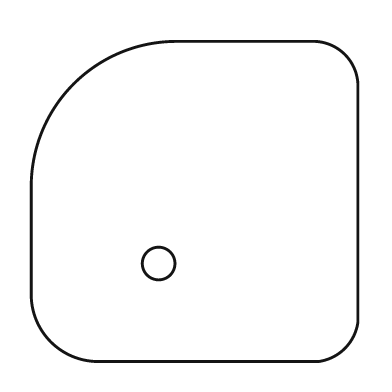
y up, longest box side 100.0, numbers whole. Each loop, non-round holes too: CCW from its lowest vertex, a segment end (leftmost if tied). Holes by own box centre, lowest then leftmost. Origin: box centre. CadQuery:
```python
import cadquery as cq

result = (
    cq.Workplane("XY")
    .moveTo(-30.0, -49.0)
    .lineTo(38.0, -49.0)
    .threePointArc((46.0, -45.0), (50.0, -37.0))
    .lineTo(50.0, 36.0)
    .threePointArc((46.0, 45.0), (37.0, 49.0))
    .lineTo(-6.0, 49.0)
    .threePointArc((-37.0, 36.0), (-50.0, 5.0))
    .lineTo(-50.0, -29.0)
    .threePointArc((-44.0, -43.0), (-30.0, -49.0))
    .close()
    .moveTo(-11.0, -19.0)
    .circle(5.0)
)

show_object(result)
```